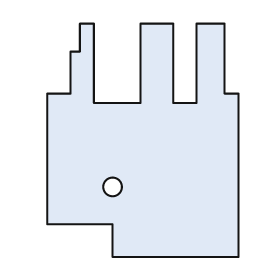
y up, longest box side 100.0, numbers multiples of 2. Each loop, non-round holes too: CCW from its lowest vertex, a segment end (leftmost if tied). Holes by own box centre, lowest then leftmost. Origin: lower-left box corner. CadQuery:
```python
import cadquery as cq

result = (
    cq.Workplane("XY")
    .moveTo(28.0, 0.0)
    .lineTo(82.0, 0.0)
    .lineTo(82.0, 70.0)
    .lineTo(76.0, 70.0)
    .lineTo(76.0, 100.0)
    .lineTo(64.0, 100.0)
    .lineTo(64.0, 66.0)
    .lineTo(54.0, 66.0)
    .lineTo(54.0, 100.0)
    .lineTo(40.0, 100.0)
    .lineTo(40.0, 66.0)
    .lineTo(20.0, 66.0)
    .lineTo(20.0, 100.0)
    .lineTo(14.0, 100.0)
    .lineTo(14.0, 88.0)
    .lineTo(10.0, 88.0)
    .lineTo(10.0, 70.0)
    .lineTo(0.0, 70.0)
    .lineTo(0.0, 14.0)
    .lineTo(28.0, 14.0)
    .close()
    .moveTo(28.0, 30.0)
    .circle(4.0)
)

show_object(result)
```